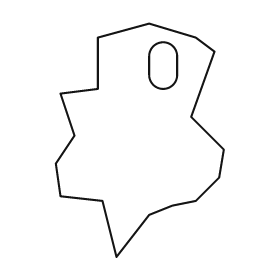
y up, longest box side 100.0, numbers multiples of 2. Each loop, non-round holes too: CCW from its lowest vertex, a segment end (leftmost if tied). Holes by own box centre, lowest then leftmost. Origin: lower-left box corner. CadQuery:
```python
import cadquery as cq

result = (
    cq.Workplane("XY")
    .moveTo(26.0, 0.0)
    .lineTo(40.0, 18.0)
    .lineTo(50.0, 22.0)
    .lineTo(60.0, 24.0)
    .lineTo(70.0, 34.0)
    .lineTo(72.0, 46.0)
    .lineTo(58.0, 60.0)
    .lineTo(68.0, 88.0)
    .lineTo(60.0, 94.0)
    .lineTo(40.0, 100.0)
    .lineTo(18.0, 94.0)
    .lineTo(18.0, 72.0)
    .lineTo(2.0, 70.0)
    .lineTo(8.0, 52.0)
    .lineTo(0.0, 40.0)
    .lineTo(2.0, 26.0)
    .lineTo(20.0, 24.0)
    .close()
    .moveTo(40.0, 78.0)
    .threePointArc((46.0, 72.0), (52.0, 78.0))
    .lineTo(52.0, 86.0)
    .threePointArc((46.0, 92.0), (40.0, 86.0))
    .close()
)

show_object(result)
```